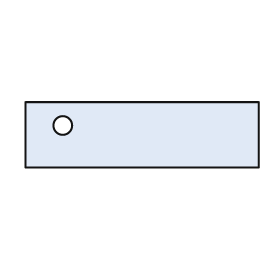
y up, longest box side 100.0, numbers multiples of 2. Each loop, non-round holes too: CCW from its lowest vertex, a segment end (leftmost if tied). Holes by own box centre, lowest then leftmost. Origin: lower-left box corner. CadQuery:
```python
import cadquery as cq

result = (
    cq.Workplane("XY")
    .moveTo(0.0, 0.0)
    .lineTo(100.0, 0.0)
    .lineTo(100.0, 28.0)
    .lineTo(0.0, 28.0)
    .close()
    .moveTo(16.0, 18.0)
    .circle(4.0)
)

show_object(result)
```